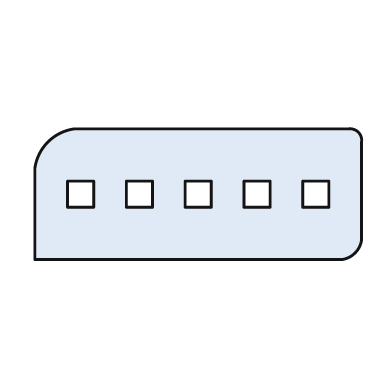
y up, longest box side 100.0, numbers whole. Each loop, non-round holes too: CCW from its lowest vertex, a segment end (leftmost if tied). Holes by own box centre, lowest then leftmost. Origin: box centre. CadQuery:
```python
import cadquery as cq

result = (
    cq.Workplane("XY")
    .moveTo(-50.0, -20.0)
    .lineTo(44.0, -20.0)
    .threePointArc((48.0, -18.0), (50.0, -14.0))
    .lineTo(50.0, 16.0)
    .threePointArc((49.0, 19.0), (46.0, 20.0))
    .lineTo(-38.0, 20.0)
    .threePointArc((-46.0, 16.0), (-50.0, 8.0))
    .close()
    .moveTo(-40.0, -4.0)
    .lineTo(-32.0, -4.0)
    .lineTo(-32.0, 4.0)
    .lineTo(-40.0, 4.0)
    .close()
    .moveTo(-22.0, -4.0)
    .lineTo(-14.0, -4.0)
    .lineTo(-14.0, 4.0)
    .lineTo(-22.0, 4.0)
    .close()
    .moveTo(-4.0, -4.0)
    .lineTo(4.0, -4.0)
    .lineTo(4.0, 4.0)
    .lineTo(-4.0, 4.0)
    .close()
    .moveTo(14.0, -4.0)
    .lineTo(22.0, -4.0)
    .lineTo(22.0, 4.0)
    .lineTo(14.0, 4.0)
    .close()
    .moveTo(32.0, -4.0)
    .lineTo(40.0, -4.0)
    .lineTo(40.0, 4.0)
    .lineTo(32.0, 4.0)
    .close()
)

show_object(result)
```